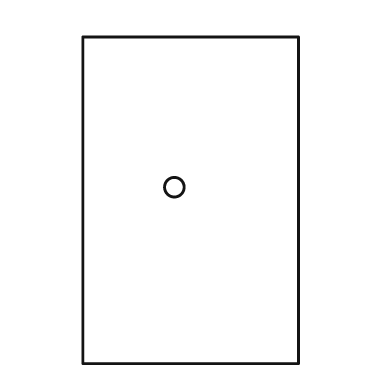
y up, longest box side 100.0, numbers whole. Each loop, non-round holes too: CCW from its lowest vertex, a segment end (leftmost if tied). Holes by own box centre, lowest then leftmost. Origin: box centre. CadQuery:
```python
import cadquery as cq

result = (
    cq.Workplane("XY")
    .moveTo(-33.0, -50.0)
    .lineTo(33.0, -50.0)
    .lineTo(33.0, 50.0)
    .lineTo(-33.0, 50.0)
    .close()
    .moveTo(-5.0, 4.0)
    .circle(3.0)
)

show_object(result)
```